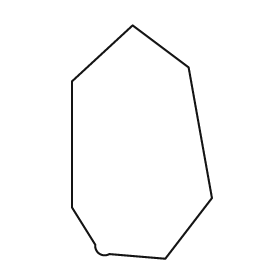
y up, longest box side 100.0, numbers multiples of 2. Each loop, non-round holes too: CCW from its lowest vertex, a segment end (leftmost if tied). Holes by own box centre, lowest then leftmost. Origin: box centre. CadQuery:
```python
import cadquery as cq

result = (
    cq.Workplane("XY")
    .moveTo(10.0, -50.0)
    .lineTo(30.0, -24.0)
    .lineTo(20.0, 32.0)
    .lineTo(-4.0, 50.0)
    .lineTo(-30.0, 26.0)
    .lineTo(-30.0, -28.0)
    .lineTo(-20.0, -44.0)
    .threePointArc((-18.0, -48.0), (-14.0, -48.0))
    .close()
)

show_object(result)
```